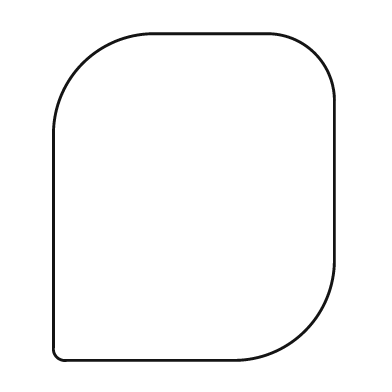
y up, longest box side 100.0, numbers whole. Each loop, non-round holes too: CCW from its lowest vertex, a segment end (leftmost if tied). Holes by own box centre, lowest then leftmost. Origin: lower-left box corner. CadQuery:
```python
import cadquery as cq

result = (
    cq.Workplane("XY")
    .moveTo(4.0, 0.0)
    .lineTo(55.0, 0.0)
    .threePointArc((77.0, 9.0), (86.0, 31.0))
    .lineTo(86.0, 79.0)
    .threePointArc((80.0, 94.0), (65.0, 100.0))
    .lineTo(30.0, 100.0)
    .threePointArc((9.0, 91.0), (0.0, 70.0))
    .lineTo(0.0, 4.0)
    .threePointArc((1.0, 1.0), (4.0, 0.0))
    .close()
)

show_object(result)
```